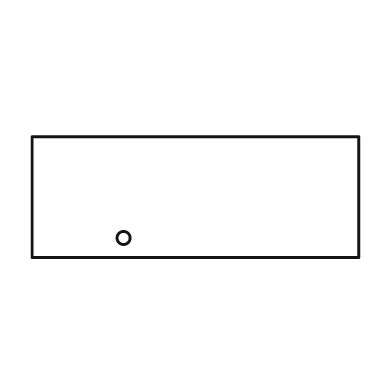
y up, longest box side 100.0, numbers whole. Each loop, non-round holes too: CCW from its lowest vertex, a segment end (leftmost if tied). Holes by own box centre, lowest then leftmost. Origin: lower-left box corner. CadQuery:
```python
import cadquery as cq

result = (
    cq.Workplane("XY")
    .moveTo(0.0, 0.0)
    .lineTo(100.0, 0.0)
    .lineTo(100.0, 37.0)
    .lineTo(0.0, 37.0)
    .close()
    .moveTo(28.0, 6.0)
    .circle(2.0)
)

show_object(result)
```